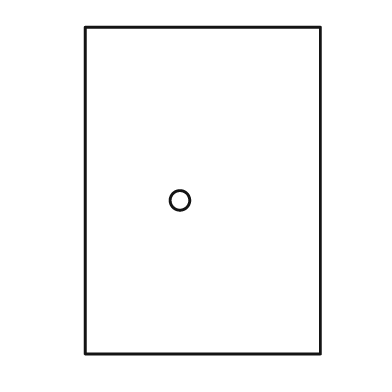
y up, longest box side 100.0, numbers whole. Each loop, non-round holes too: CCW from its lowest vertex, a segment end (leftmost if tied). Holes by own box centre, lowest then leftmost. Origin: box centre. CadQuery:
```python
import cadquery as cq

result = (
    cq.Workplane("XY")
    .moveTo(-36.0, -50.0)
    .lineTo(36.0, -50.0)
    .lineTo(36.0, 50.0)
    .lineTo(-36.0, 50.0)
    .close()
    .moveTo(-7.0, -3.0)
    .circle(3.0)
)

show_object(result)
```